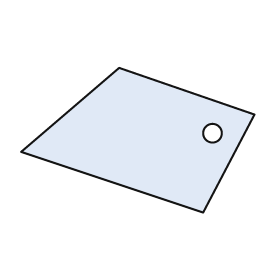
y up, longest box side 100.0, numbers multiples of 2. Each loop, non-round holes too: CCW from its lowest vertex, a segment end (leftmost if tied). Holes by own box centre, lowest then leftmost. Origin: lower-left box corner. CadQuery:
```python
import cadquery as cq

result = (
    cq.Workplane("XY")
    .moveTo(78.0, 0.0)
    .lineTo(100.0, 42.0)
    .lineTo(42.0, 62.0)
    .lineTo(0.0, 26.0)
    .close()
    .moveTo(82.0, 34.0)
    .circle(4.0)
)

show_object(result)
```